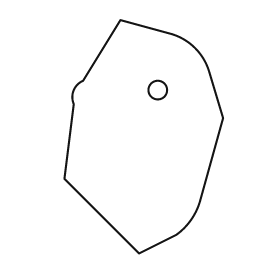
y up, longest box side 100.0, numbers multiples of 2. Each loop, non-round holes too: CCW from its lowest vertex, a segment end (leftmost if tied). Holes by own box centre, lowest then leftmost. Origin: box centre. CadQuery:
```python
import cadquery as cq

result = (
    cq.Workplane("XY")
    .moveTo(-2.0, -50.0)
    .lineTo(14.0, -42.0)
    .threePointArc((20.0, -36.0), (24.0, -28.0))
    .lineTo(34.0, 8.0)
    .lineTo(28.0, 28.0)
    .threePointArc((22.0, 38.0), (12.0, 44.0))
    .lineTo(-10.0, 50.0)
    .lineTo(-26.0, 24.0)
    .threePointArc((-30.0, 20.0), (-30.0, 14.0))
    .lineTo(-34.0, -18.0)
    .close()
    .moveTo(6.0, 20.0)
    .circle(4.0)
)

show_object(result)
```